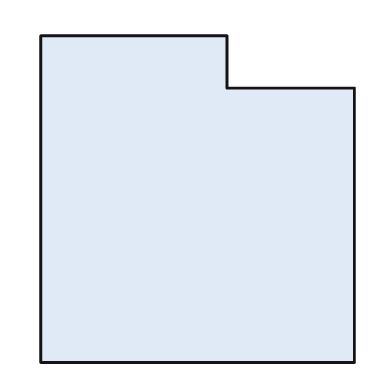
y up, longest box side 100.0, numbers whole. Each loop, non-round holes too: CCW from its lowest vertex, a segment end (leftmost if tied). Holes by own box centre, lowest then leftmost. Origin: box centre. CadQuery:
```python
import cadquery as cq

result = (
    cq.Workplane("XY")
    .moveTo(-48.0, -50.0)
    .lineTo(48.0, -50.0)
    .lineTo(48.0, 34.0)
    .lineTo(9.0, 34.0)
    .lineTo(9.0, 50.0)
    .lineTo(-48.0, 50.0)
    .close()
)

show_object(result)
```